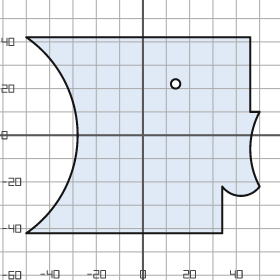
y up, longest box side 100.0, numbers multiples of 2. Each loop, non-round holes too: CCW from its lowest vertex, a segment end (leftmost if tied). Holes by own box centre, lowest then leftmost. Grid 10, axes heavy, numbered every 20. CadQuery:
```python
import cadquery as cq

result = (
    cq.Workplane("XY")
    .moveTo(-50.0, -42.0)
    .lineTo(34.0, -42.0)
    .lineTo(34.0, -22.0)
    .threePointArc((42.0, -26.0), (50.0, -22.0))
    .threePointArc((46.0, -6.0), (50.0, 10.0))
    .lineTo(46.0, 10.0)
    .lineTo(46.0, 42.0)
    .lineTo(-50.0, 42.0)
    .threePointArc((-28.0, 0.0), (-50.0, -42.0))
    .close()
    .moveTo(14.0, 22.0)
    .circle(2.0)
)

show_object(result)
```